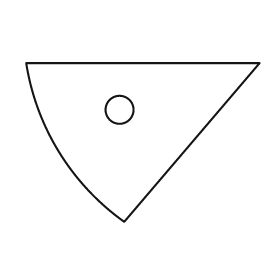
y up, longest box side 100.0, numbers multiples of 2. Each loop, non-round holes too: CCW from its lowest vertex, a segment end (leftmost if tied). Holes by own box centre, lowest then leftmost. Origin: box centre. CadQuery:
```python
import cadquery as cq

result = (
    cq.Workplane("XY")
    .moveTo(-8.0, -34.0)
    .lineTo(50.0, 34.0)
    .lineTo(-50.0, 34.0)
    .threePointArc((-36.0, -4.0), (-8.0, -34.0))
    .close()
    .moveTo(-10.0, 14.0)
    .circle(6.0)
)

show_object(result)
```